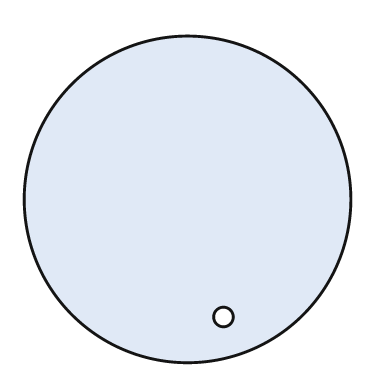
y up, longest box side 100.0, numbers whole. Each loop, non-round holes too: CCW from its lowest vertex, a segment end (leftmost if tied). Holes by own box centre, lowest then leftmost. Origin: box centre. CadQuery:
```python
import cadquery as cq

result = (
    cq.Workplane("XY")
    .moveTo(0.0, 0.0)
    .circle(50.0)
    .moveTo(11.0, -36.0)
    .circle(3.0)
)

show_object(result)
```